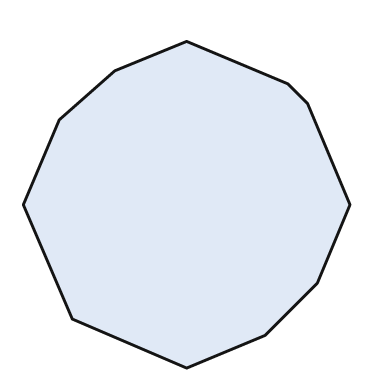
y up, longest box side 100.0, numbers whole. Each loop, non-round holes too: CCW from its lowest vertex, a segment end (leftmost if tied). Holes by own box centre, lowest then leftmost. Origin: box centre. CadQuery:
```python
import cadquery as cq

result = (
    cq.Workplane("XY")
    .moveTo(0.0, -50.0)
    .lineTo(24.0, -40.0)
    .lineTo(40.0, -24.0)
    .lineTo(50.0, 0.0)
    .lineTo(37.0, 31.0)
    .lineTo(31.0, 37.0)
    .lineTo(0.0, 50.0)
    .lineTo(-22.0, 41.0)
    .lineTo(-39.0, 26.0)
    .lineTo(-50.0, 0.0)
    .lineTo(-35.0, -35.0)
    .close()
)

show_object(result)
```